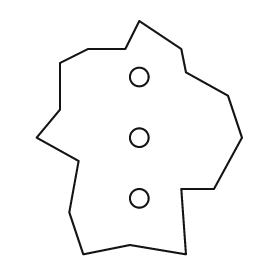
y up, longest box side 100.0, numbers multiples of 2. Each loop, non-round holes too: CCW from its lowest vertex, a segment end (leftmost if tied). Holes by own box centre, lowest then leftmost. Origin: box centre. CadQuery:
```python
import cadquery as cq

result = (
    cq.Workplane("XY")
    .moveTo(-24.0, -50.0)
    .lineTo(-4.0, -46.0)
    .lineTo(20.0, -50.0)
    .lineTo(18.0, -22.0)
    .lineTo(32.0, -22.0)
    .lineTo(44.0, 0.0)
    .lineTo(38.0, 18.0)
    .lineTo(20.0, 28.0)
    .lineTo(18.0, 38.0)
    .lineTo(0.0, 50.0)
    .lineTo(-6.0, 38.0)
    .lineTo(-22.0, 38.0)
    .lineTo(-34.0, 32.0)
    .lineTo(-34.0, 12.0)
    .lineTo(-44.0, 0.0)
    .lineTo(-26.0, -10.0)
    .lineTo(-30.0, -32.0)
    .close()
    .moveTo(0.0, -26.0)
    .circle(4.0)
    .moveTo(0.0, 0.0)
    .circle(4.0)
    .moveTo(0.0, 26.0)
    .circle(4.0)
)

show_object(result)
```